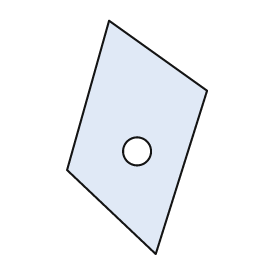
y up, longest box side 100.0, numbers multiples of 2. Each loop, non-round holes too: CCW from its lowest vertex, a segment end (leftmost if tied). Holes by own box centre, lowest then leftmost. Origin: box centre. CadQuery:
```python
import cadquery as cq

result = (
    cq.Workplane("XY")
    .moveTo(8.0, -50.0)
    .lineTo(30.0, 20.0)
    .lineTo(-12.0, 50.0)
    .lineTo(-30.0, -14.0)
    .close()
    .moveTo(0.0, -6.0)
    .circle(6.0)
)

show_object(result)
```